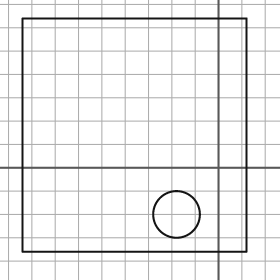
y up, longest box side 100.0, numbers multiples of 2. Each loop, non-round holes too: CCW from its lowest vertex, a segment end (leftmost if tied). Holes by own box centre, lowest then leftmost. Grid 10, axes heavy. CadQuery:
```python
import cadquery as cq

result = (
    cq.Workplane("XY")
    .moveTo(-84.0, -36.0)
    .lineTo(12.0, -36.0)
    .lineTo(12.0, 64.0)
    .lineTo(-84.0, 64.0)
    .close()
    .moveTo(-18.0, -20.0)
    .circle(10.0)
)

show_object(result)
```